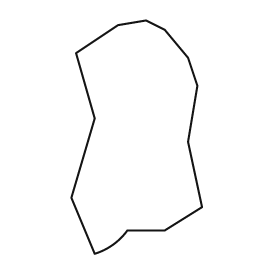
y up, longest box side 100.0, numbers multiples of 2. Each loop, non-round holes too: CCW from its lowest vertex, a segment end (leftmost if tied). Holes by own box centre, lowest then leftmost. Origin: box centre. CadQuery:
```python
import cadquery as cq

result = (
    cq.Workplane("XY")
    .moveTo(-18.0, -50.0)
    .threePointArc((-10.0, -46.0), (-4.0, -40.0))
    .lineTo(12.0, -40.0)
    .lineTo(28.0, -30.0)
    .lineTo(22.0, -2.0)
    .lineTo(26.0, 22.0)
    .lineTo(22.0, 34.0)
    .lineTo(12.0, 46.0)
    .lineTo(4.0, 50.0)
    .lineTo(-8.0, 48.0)
    .lineTo(-26.0, 36.0)
    .lineTo(-18.0, 8.0)
    .lineTo(-28.0, -26.0)
    .close()
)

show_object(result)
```